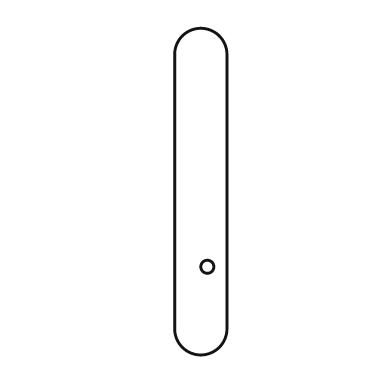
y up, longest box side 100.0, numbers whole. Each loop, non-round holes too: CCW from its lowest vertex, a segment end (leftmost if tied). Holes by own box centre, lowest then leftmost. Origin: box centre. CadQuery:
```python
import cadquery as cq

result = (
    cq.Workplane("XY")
    .moveTo(-8.0, -42.0)
    .threePointArc((0.0, -50.0), (8.0, -42.0))
    .lineTo(8.0, 42.0)
    .threePointArc((0.0, 50.0), (-8.0, 42.0))
    .close()
    .moveTo(2.0, -23.0)
    .circle(2.0)
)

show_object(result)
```